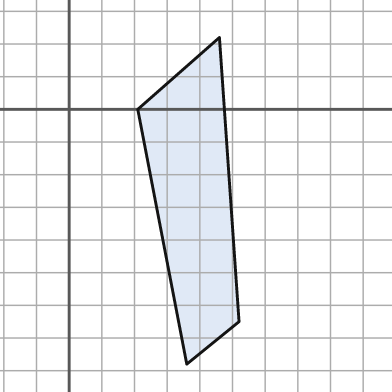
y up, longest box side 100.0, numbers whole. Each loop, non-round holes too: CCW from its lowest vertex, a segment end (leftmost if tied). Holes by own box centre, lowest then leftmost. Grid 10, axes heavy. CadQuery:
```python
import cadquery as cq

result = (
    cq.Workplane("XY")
    .moveTo(36.0, -78.0)
    .lineTo(52.0, -65.0)
    .lineTo(46.0, 22.0)
    .lineTo(21.0, 0.0)
    .close()
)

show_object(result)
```